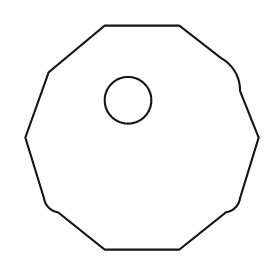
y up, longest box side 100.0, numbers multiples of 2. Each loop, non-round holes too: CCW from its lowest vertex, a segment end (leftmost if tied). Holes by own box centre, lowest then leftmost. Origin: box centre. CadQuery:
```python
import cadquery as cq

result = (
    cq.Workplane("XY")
    .moveTo(-16.0, -48.0)
    .lineTo(16.0, -48.0)
    .lineTo(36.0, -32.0)
    .threePointArc((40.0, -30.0), (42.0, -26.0))
    .lineTo(50.0, 0.0)
    .lineTo(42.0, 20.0)
    .threePointArc((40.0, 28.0), (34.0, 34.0))
    .lineTo(16.0, 48.0)
    .lineTo(-16.0, 48.0)
    .lineTo(-40.0, 28.0)
    .lineTo(-50.0, 0.0)
    .lineTo(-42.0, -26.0)
    .threePointArc((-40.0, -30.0), (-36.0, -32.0))
    .close()
    .moveTo(-6.0, 16.0)
    .circle(10.0)
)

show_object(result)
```